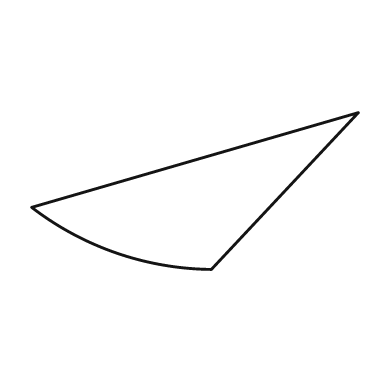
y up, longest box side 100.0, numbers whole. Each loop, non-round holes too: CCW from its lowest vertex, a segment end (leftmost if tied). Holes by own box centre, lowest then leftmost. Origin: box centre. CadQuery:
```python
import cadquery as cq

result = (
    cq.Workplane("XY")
    .moveTo(5.0, -24.0)
    .lineTo(50.0, 24.0)
    .lineTo(-50.0, -5.0)
    .threePointArc((-24.0, -19.0), (5.0, -24.0))
    .close()
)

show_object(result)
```